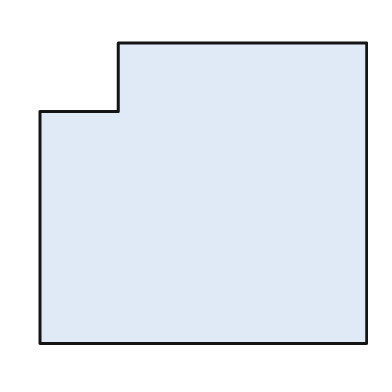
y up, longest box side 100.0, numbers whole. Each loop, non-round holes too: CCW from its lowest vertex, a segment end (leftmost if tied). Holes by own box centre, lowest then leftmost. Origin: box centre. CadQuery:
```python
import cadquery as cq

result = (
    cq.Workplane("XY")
    .moveTo(-50.0, -46.0)
    .lineTo(50.0, -46.0)
    .lineTo(50.0, 46.0)
    .lineTo(-26.0, 46.0)
    .lineTo(-26.0, 25.0)
    .lineTo(-50.0, 25.0)
    .close()
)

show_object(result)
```